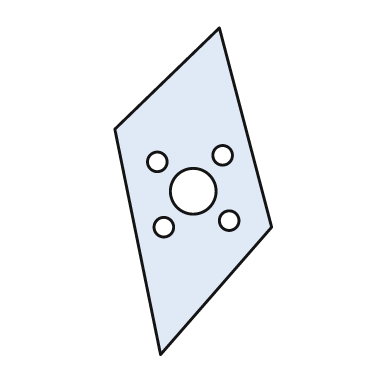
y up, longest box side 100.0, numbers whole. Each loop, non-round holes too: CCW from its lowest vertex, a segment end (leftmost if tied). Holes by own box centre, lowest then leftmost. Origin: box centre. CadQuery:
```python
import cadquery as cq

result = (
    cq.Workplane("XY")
    .moveTo(-10.0, -50.0)
    .lineTo(24.0, -11.0)
    .lineTo(8.0, 50.0)
    .lineTo(-24.0, 19.0)
    .close()
    .moveTo(-9.0, -11.0)
    .circle(3.0)
    .moveTo(11.0, -9.0)
    .circle(3.0)
    .moveTo(0.0, 0.0)
    .circle(7.0)
    .moveTo(-11.0, 9.0)
    .circle(3.0)
    .moveTo(9.0, 11.0)
    .circle(3.0)
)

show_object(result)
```